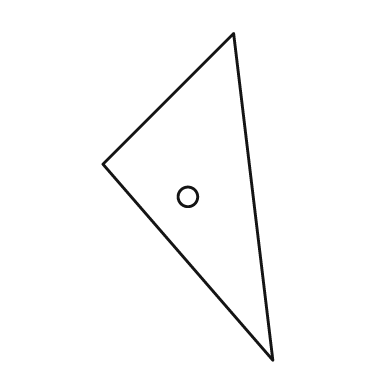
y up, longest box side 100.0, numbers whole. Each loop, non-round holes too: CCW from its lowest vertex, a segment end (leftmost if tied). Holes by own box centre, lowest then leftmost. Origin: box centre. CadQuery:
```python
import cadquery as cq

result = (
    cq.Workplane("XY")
    .moveTo(26.0, -50.0)
    .lineTo(14.0, 50.0)
    .lineTo(-26.0, 10.0)
    .close()
    .moveTo(0.0, 0.0)
    .circle(3.0)
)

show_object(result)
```